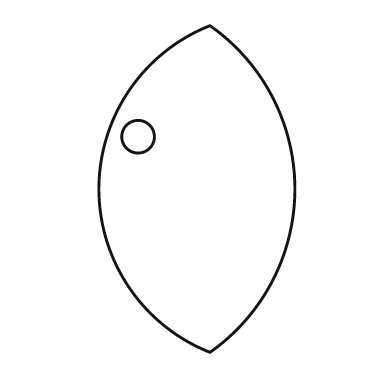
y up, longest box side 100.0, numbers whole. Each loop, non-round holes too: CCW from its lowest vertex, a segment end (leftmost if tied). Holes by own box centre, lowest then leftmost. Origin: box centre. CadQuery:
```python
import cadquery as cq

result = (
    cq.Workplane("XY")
    .moveTo(4.0, -50.0)
    .threePointArc((30.0, 0.0), (4.0, 50.0))
    .threePointArc((-30.0, 0.0), (4.0, -50.0))
    .close()
    .moveTo(-18.0, 16.0)
    .circle(5.0)
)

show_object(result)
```